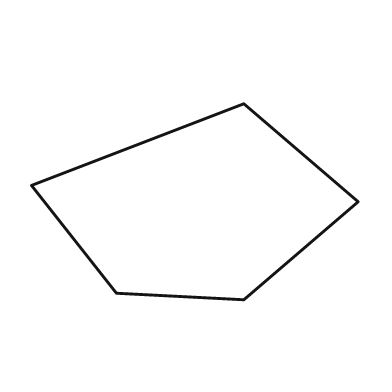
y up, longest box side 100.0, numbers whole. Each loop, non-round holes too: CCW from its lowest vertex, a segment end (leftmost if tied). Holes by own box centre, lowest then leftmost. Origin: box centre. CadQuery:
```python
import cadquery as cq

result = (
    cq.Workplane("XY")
    .moveTo(15.0, -30.0)
    .lineTo(50.0, 0.0)
    .lineTo(15.0, 30.0)
    .lineTo(-50.0, 5.0)
    .lineTo(-24.0, -28.0)
    .close()
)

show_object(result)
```